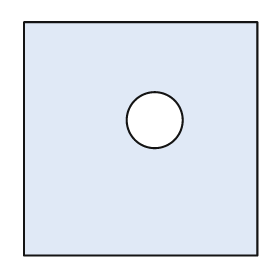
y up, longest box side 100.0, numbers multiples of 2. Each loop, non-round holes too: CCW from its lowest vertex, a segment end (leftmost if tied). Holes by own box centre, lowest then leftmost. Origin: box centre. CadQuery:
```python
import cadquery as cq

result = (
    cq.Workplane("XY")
    .moveTo(-50.0, -50.0)
    .lineTo(50.0, -50.0)
    .lineTo(50.0, 50.0)
    .lineTo(-50.0, 50.0)
    .close()
    .moveTo(6.0, 8.0)
    .circle(12.0)
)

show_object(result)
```